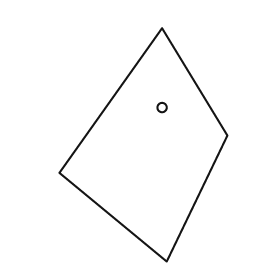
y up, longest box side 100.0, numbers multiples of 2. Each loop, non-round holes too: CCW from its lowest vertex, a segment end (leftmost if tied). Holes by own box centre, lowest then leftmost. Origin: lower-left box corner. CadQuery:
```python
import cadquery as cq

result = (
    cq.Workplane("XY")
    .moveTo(46.0, 0.0)
    .lineTo(72.0, 54.0)
    .lineTo(44.0, 100.0)
    .lineTo(0.0, 38.0)
    .close()
    .moveTo(44.0, 66.0)
    .circle(2.0)
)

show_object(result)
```